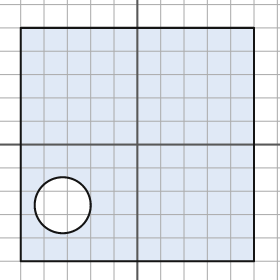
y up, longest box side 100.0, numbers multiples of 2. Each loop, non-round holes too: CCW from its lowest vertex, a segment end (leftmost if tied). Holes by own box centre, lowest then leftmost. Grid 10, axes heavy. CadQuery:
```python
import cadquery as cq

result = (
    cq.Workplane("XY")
    .moveTo(-50.0, -50.0)
    .lineTo(50.0, -50.0)
    .lineTo(50.0, 50.0)
    .lineTo(-50.0, 50.0)
    .close()
    .moveTo(-32.0, -26.0)
    .circle(12.0)
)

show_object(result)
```